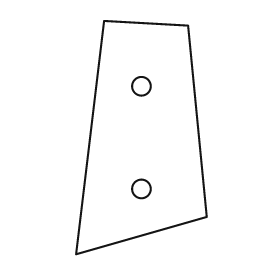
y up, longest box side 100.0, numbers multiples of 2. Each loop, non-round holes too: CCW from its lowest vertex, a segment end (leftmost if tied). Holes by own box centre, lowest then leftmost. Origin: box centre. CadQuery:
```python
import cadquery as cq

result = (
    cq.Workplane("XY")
    .moveTo(-28.0, -50.0)
    .lineTo(28.0, -34.0)
    .lineTo(20.0, 48.0)
    .lineTo(-16.0, 50.0)
    .close()
    .moveTo(0.0, -22.0)
    .circle(4.0)
    .moveTo(0.0, 22.0)
    .circle(4.0)
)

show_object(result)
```